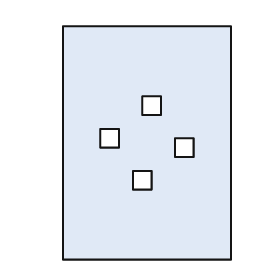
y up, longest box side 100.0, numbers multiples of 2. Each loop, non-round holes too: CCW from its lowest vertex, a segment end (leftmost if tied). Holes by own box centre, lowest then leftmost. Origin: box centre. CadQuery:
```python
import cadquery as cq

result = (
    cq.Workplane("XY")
    .moveTo(-36.0, -50.0)
    .lineTo(36.0, -50.0)
    .lineTo(36.0, 50.0)
    .lineTo(-36.0, 50.0)
    .close()
    .moveTo(-6.0, -20.0)
    .lineTo(2.0, -20.0)
    .lineTo(2.0, -12.0)
    .lineTo(-6.0, -12.0)
    .close()
    .moveTo(12.0, -6.0)
    .lineTo(20.0, -6.0)
    .lineTo(20.0, 2.0)
    .lineTo(12.0, 2.0)
    .close()
    .moveTo(-20.0, -2.0)
    .lineTo(-12.0, -2.0)
    .lineTo(-12.0, 6.0)
    .lineTo(-20.0, 6.0)
    .close()
    .moveTo(-2.0, 12.0)
    .lineTo(6.0, 12.0)
    .lineTo(6.0, 20.0)
    .lineTo(-2.0, 20.0)
    .close()
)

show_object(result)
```